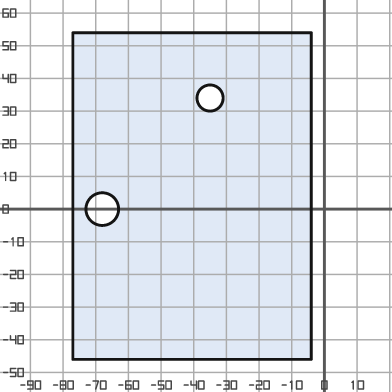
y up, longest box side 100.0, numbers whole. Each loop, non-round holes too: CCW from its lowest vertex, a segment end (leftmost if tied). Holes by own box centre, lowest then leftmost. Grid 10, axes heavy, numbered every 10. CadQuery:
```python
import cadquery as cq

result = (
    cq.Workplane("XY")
    .moveTo(-77.0, -46.0)
    .lineTo(-4.0, -46.0)
    .lineTo(-4.0, 54.0)
    .lineTo(-77.0, 54.0)
    .close()
    .moveTo(-68.0, 0.0)
    .circle(5.0)
    .moveTo(-35.0, 34.0)
    .circle(4.0)
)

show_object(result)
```